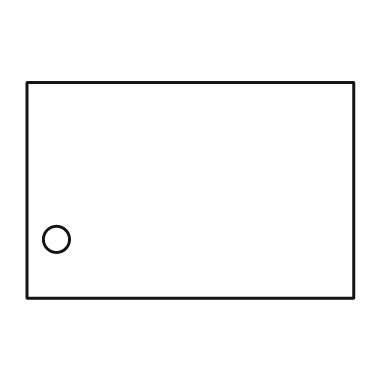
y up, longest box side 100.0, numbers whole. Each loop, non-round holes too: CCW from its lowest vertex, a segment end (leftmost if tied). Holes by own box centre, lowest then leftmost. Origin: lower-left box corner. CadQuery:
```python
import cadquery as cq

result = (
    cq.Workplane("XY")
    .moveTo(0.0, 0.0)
    .lineTo(100.0, 0.0)
    .lineTo(100.0, 66.0)
    .lineTo(0.0, 66.0)
    .close()
    .moveTo(9.0, 18.0)
    .circle(4.0)
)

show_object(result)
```